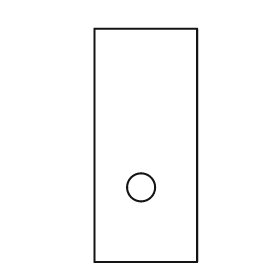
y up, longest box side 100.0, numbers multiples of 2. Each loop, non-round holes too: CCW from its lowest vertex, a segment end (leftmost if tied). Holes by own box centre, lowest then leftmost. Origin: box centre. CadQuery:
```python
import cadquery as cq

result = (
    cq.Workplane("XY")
    .moveTo(-22.0, -50.0)
    .lineTo(22.0, -50.0)
    .lineTo(22.0, 50.0)
    .lineTo(-22.0, 50.0)
    .close()
    .moveTo(-2.0, -18.0)
    .circle(6.0)
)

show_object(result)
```